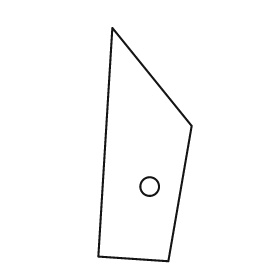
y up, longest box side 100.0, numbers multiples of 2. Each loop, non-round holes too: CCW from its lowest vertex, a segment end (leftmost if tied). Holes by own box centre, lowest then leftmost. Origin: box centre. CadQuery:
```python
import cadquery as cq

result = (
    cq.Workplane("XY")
    .moveTo(10.0, -50.0)
    .lineTo(20.0, 8.0)
    .lineTo(-14.0, 50.0)
    .lineTo(-20.0, -48.0)
    .close()
    .moveTo(2.0, -18.0)
    .circle(4.0)
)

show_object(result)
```